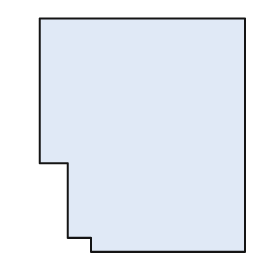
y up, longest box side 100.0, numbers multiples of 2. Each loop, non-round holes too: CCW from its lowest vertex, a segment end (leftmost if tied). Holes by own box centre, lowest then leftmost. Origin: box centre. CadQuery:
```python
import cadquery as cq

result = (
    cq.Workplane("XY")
    .moveTo(-22.0, -50.0)
    .lineTo(44.0, -50.0)
    .lineTo(44.0, 50.0)
    .lineTo(-44.0, 50.0)
    .lineTo(-44.0, -12.0)
    .lineTo(-32.0, -12.0)
    .lineTo(-32.0, -44.0)
    .lineTo(-22.0, -44.0)
    .close()
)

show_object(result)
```